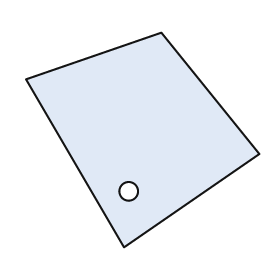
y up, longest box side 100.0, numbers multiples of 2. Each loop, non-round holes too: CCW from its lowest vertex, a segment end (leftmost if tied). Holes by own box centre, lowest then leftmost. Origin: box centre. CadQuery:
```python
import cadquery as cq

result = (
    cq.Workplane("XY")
    .moveTo(-8.0, -46.0)
    .lineTo(50.0, -6.0)
    .lineTo(8.0, 46.0)
    .lineTo(-50.0, 26.0)
    .close()
    .moveTo(-6.0, -22.0)
    .circle(4.0)
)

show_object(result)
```